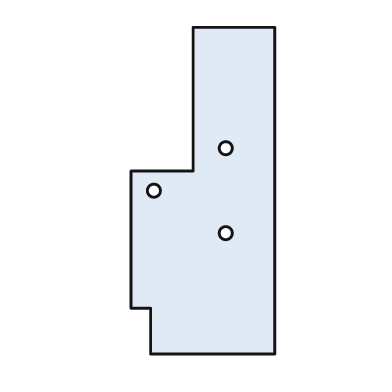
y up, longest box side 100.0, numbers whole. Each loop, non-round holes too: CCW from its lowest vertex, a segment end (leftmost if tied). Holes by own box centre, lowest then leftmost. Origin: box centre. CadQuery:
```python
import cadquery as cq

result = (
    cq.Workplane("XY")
    .moveTo(-16.0, -50.0)
    .lineTo(22.0, -50.0)
    .lineTo(22.0, 50.0)
    .lineTo(-3.0, 50.0)
    .lineTo(-3.0, 6.0)
    .lineTo(-22.0, 6.0)
    .lineTo(-22.0, -36.0)
    .lineTo(-16.0, -36.0)
    .close()
    .moveTo(7.0, -13.0)
    .circle(2.0)
    .moveTo(-15.0, 0.0)
    .circle(2.0)
    .moveTo(7.0, 13.0)
    .circle(2.0)
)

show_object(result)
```